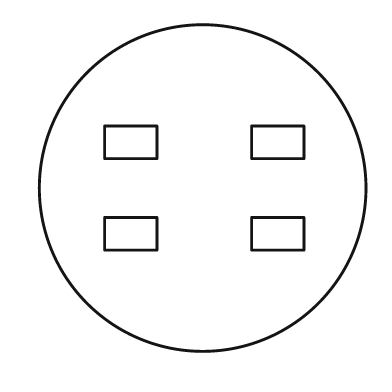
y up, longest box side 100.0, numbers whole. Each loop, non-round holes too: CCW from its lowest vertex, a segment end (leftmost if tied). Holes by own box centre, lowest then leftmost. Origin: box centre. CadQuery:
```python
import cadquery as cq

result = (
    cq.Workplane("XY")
    .moveTo(0.0, 0.0)
    .circle(50.0)
    .moveTo(-30.0, -19.0)
    .lineTo(-14.0, -19.0)
    .lineTo(-14.0, -9.0)
    .lineTo(-30.0, -9.0)
    .close()
    .moveTo(15.0, -19.0)
    .lineTo(31.0, -19.0)
    .lineTo(31.0, -9.0)
    .lineTo(15.0, -9.0)
    .close()
    .moveTo(-30.0, 9.0)
    .lineTo(-14.0, 9.0)
    .lineTo(-14.0, 19.0)
    .lineTo(-30.0, 19.0)
    .close()
    .moveTo(15.0, 9.0)
    .lineTo(31.0, 9.0)
    .lineTo(31.0, 19.0)
    .lineTo(15.0, 19.0)
    .close()
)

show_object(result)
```